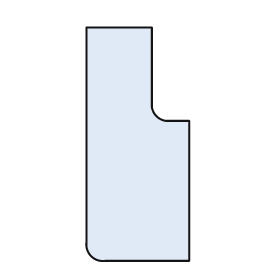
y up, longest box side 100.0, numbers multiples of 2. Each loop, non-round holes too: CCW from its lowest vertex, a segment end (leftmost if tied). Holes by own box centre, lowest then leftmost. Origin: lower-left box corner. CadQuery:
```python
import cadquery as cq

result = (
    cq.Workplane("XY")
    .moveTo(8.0, 0.0)
    .lineTo(44.0, 0.0)
    .lineTo(44.0, 60.0)
    .lineTo(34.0, 60.0)
    .threePointArc((30.0, 62.0), (28.0, 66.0))
    .lineTo(28.0, 100.0)
    .lineTo(0.0, 100.0)
    .lineTo(0.0, 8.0)
    .threePointArc((2.0, 2.0), (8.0, 0.0))
    .close()
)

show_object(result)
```